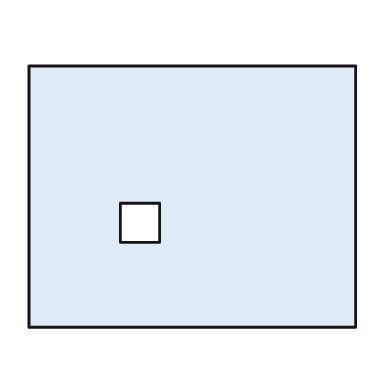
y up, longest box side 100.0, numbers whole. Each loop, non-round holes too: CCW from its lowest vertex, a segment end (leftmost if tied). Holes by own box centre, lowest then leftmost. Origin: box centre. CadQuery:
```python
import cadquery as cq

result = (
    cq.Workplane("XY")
    .moveTo(-50.0, -40.0)
    .lineTo(50.0, -40.0)
    .lineTo(50.0, 40.0)
    .lineTo(-50.0, 40.0)
    .close()
    .moveTo(-22.0, -14.0)
    .lineTo(-10.0, -14.0)
    .lineTo(-10.0, -2.0)
    .lineTo(-22.0, -2.0)
    .close()
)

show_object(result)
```